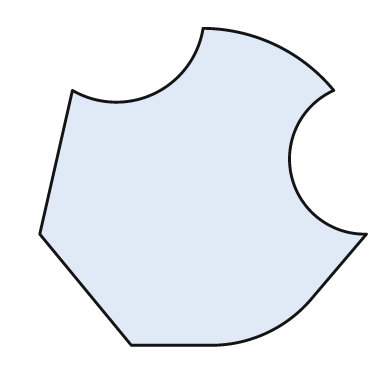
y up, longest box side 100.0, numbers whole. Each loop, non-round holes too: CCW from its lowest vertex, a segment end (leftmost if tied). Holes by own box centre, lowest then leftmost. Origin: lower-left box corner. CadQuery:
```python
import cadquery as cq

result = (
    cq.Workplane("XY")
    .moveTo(28.0, 0.0)
    .lineTo(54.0, 0.0)
    .threePointArc((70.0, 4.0), (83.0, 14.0))
    .lineTo(100.0, 34.0)
    .threePointArc((77.0, 52.0), (90.0, 78.0))
    .threePointArc((72.0, 92.0), (50.0, 97.0))
    .threePointArc((35.0, 77.0), (10.0, 78.0))
    .lineTo(0.0, 34.0)
    .close()
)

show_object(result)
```